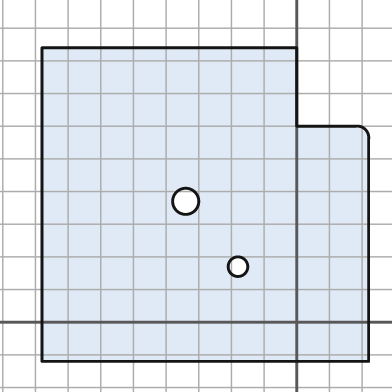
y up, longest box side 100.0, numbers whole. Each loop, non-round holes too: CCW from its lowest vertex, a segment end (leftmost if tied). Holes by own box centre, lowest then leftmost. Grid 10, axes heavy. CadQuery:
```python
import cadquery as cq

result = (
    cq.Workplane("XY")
    .moveTo(-78.0, -12.0)
    .lineTo(22.0, -12.0)
    .lineTo(22.0, 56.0)
    .threePointArc((21.0, 59.0), (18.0, 60.0))
    .lineTo(0.0, 60.0)
    .lineTo(0.0, 84.0)
    .lineTo(-78.0, 84.0)
    .close()
    .moveTo(-18.0, 17.0)
    .circle(3.0)
    .moveTo(-34.0, 37.0)
    .circle(4.0)
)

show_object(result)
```